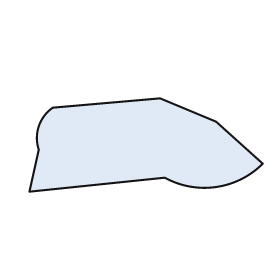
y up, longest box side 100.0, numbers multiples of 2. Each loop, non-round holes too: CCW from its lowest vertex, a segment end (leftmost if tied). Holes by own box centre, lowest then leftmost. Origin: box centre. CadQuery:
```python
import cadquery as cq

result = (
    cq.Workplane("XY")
    .moveTo(-50.0, -20.0)
    .lineTo(8.0, -14.0)
    .threePointArc((30.0, -18.0), (50.0, -8.0))
    .lineTo(30.0, 10.0)
    .lineTo(6.0, 20.0)
    .lineTo(-40.0, 16.0)
    .threePointArc((-46.0, 8.0), (-46.0, -2.0))
    .close()
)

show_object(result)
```